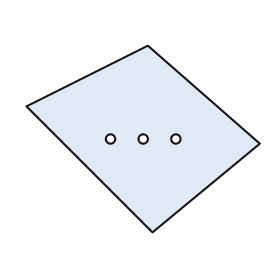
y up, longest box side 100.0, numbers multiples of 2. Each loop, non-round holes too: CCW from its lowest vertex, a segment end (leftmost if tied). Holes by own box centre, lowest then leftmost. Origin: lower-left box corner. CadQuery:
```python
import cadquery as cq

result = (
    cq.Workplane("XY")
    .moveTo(54.0, 0.0)
    .lineTo(100.0, 38.0)
    .lineTo(52.0, 80.0)
    .lineTo(0.0, 54.0)
    .close()
    .moveTo(36.0, 40.0)
    .circle(2.0)
    .moveTo(50.0, 40.0)
    .circle(2.0)
    .moveTo(64.0, 40.0)
    .circle(2.0)
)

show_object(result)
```